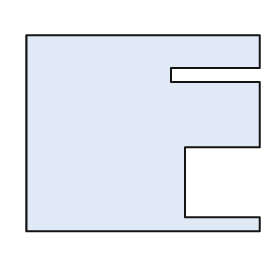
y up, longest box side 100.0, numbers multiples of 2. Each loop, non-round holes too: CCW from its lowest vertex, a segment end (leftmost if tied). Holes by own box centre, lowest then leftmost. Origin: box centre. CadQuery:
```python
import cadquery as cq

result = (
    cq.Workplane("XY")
    .moveTo(-50.0, -42.0)
    .lineTo(50.0, -42.0)
    .lineTo(50.0, -36.0)
    .lineTo(18.0, -36.0)
    .lineTo(18.0, -6.0)
    .lineTo(50.0, -6.0)
    .lineTo(50.0, 22.0)
    .lineTo(12.0, 22.0)
    .lineTo(12.0, 28.0)
    .lineTo(50.0, 28.0)
    .lineTo(50.0, 42.0)
    .lineTo(-50.0, 42.0)
    .close()
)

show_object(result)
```